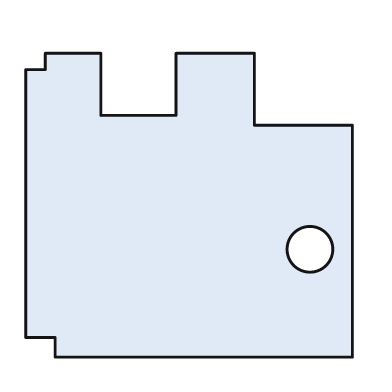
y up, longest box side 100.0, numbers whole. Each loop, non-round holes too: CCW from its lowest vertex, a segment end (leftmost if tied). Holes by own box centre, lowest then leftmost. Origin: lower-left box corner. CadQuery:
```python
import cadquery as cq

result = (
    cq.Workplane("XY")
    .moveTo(9.0, 0.0)
    .lineTo(100.0, 0.0)
    .lineTo(100.0, 71.0)
    .lineTo(70.0, 71.0)
    .lineTo(70.0, 93.0)
    .lineTo(46.0, 93.0)
    .lineTo(46.0, 74.0)
    .lineTo(23.0, 74.0)
    .lineTo(23.0, 93.0)
    .lineTo(6.0, 93.0)
    .lineTo(6.0, 88.0)
    .lineTo(0.0, 88.0)
    .lineTo(0.0, 6.0)
    .lineTo(9.0, 6.0)
    .close()
    .moveTo(87.0, 33.0)
    .circle(7.0)
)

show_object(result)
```